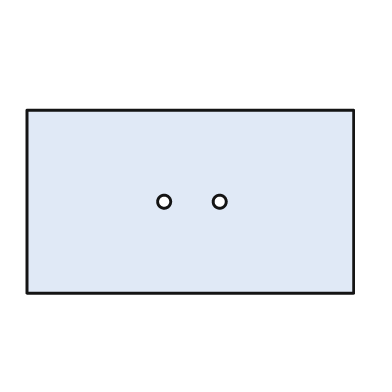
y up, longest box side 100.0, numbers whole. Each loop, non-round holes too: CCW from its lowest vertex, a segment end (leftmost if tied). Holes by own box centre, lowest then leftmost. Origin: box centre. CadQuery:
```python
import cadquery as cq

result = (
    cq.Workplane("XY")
    .moveTo(-50.0, -28.0)
    .lineTo(50.0, -28.0)
    .lineTo(50.0, 28.0)
    .lineTo(-50.0, 28.0)
    .close()
    .moveTo(-8.0, 0.0)
    .circle(2.0)
    .moveTo(9.0, 0.0)
    .circle(2.0)
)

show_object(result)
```